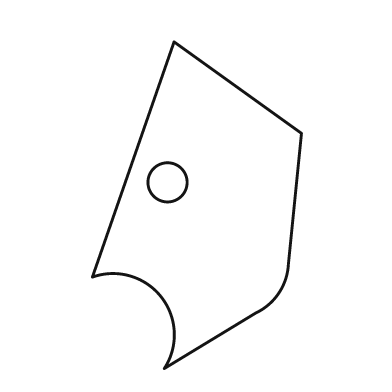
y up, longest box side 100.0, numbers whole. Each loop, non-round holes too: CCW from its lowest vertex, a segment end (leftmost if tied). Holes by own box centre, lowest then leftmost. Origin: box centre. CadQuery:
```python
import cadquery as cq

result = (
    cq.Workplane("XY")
    .moveTo(-10.0, -50.0)
    .lineTo(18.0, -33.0)
    .threePointArc((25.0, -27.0), (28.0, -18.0))
    .lineTo(32.0, 22.0)
    .lineTo(-7.0, 50.0)
    .lineTo(-32.0, -22.0)
    .threePointArc((-11.0, -28.0), (-10.0, -50.0))
    .close()
    .moveTo(-9.0, 7.0)
    .circle(6.0)
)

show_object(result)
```